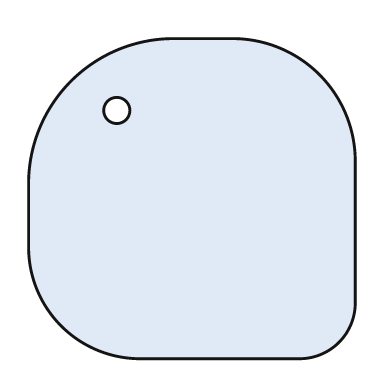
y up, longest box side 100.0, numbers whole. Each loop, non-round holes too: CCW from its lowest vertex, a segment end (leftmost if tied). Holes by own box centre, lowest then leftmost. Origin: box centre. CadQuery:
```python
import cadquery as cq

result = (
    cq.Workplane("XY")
    .moveTo(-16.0, -49.0)
    .lineTo(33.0, -49.0)
    .threePointArc((45.0, -44.0), (50.0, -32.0))
    .lineTo(50.0, 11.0)
    .threePointArc((39.0, 38.0), (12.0, 49.0))
    .lineTo(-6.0, 49.0)
    .threePointArc((-37.0, 36.0), (-50.0, 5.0))
    .lineTo(-50.0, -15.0)
    .threePointArc((-40.0, -39.0), (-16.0, -49.0))
    .close()
    .moveTo(-23.0, 27.0)
    .circle(4.0)
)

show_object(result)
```